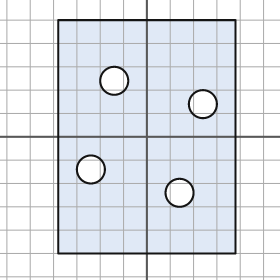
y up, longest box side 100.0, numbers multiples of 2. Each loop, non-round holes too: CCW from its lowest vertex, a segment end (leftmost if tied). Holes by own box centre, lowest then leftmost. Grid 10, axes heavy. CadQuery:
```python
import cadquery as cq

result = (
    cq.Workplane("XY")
    .moveTo(-38.0, -50.0)
    .lineTo(38.0, -50.0)
    .lineTo(38.0, 50.0)
    .lineTo(-38.0, 50.0)
    .close()
    .moveTo(14.0, -24.0)
    .circle(6.0)
    .moveTo(-24.0, -14.0)
    .circle(6.0)
    .moveTo(24.0, 14.0)
    .circle(6.0)
    .moveTo(-14.0, 24.0)
    .circle(6.0)
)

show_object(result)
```